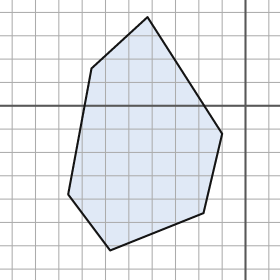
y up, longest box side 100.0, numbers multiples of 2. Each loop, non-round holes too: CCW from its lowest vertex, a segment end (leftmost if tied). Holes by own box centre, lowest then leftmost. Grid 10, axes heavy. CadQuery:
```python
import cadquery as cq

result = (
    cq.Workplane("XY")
    .moveTo(-58.0, -62.0)
    .lineTo(-18.0, -46.0)
    .lineTo(-10.0, -12.0)
    .lineTo(-42.0, 38.0)
    .lineTo(-66.0, 16.0)
    .lineTo(-76.0, -38.0)
    .close()
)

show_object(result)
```